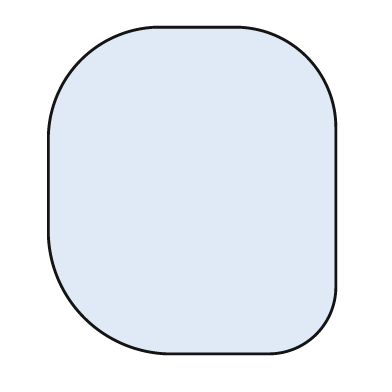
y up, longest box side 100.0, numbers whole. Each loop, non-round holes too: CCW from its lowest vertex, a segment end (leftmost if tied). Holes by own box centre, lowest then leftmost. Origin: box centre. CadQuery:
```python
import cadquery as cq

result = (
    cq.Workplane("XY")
    .moveTo(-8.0, -50.0)
    .lineTo(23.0, -50.0)
    .threePointArc((38.0, -44.0), (44.0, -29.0))
    .lineTo(44.0, 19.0)
    .threePointArc((35.0, 41.0), (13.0, 50.0))
    .lineTo(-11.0, 50.0)
    .threePointArc((-34.0, 40.0), (-44.0, 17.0))
    .lineTo(-44.0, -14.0)
    .threePointArc((-33.0, -39.0), (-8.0, -50.0))
    .close()
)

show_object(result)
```